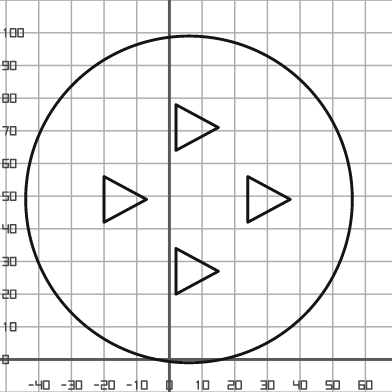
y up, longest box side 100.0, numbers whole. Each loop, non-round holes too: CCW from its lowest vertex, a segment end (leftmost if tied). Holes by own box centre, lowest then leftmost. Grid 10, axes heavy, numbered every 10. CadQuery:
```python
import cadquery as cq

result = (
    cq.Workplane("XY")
    .moveTo(6.0, 49.0)
    .circle(50.0)
    .moveTo(2.0, 20.0)
    .lineTo(15.0, 27.0)
    .lineTo(2.0, 34.0)
    .close()
    .moveTo(-20.0, 42.0)
    .lineTo(-7.0, 49.0)
    .lineTo(-20.0, 56.0)
    .close()
    .moveTo(24.0, 42.0)
    .lineTo(37.0, 49.0)
    .lineTo(24.0, 56.0)
    .close()
    .moveTo(2.0, 64.0)
    .lineTo(15.0, 71.0)
    .lineTo(2.0, 78.0)
    .close()
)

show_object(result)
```